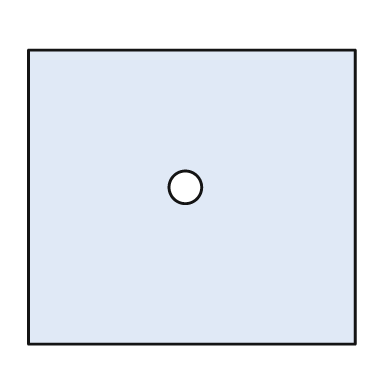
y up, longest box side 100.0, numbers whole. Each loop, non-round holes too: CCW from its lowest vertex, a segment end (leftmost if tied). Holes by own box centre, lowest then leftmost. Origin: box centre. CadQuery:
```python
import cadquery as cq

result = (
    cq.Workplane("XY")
    .moveTo(-50.0, -45.0)
    .lineTo(50.0, -45.0)
    .lineTo(50.0, 45.0)
    .lineTo(-50.0, 45.0)
    .close()
    .moveTo(-2.0, 3.0)
    .circle(5.0)
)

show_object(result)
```